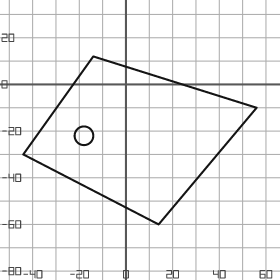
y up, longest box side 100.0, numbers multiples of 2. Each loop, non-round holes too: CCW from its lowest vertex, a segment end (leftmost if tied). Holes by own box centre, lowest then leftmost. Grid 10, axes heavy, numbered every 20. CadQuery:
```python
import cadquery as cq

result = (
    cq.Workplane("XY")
    .moveTo(14.0, -60.0)
    .lineTo(56.0, -10.0)
    .lineTo(-14.0, 12.0)
    .lineTo(-44.0, -30.0)
    .close()
    .moveTo(-18.0, -22.0)
    .circle(4.0)
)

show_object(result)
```